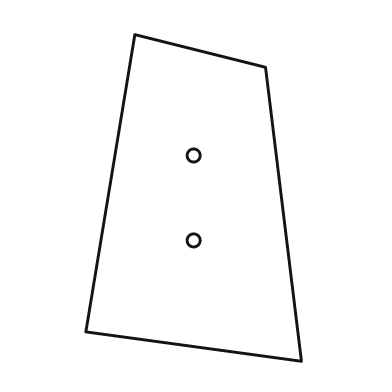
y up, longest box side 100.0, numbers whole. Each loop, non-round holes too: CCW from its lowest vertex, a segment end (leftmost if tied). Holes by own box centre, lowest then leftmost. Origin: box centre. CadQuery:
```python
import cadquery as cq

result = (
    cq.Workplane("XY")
    .moveTo(33.0, -50.0)
    .lineTo(22.0, 40.0)
    .lineTo(-18.0, 50.0)
    .lineTo(-33.0, -41.0)
    .close()
    .moveTo(0.0, -13.0)
    .circle(2.0)
    .moveTo(0.0, 13.0)
    .circle(2.0)
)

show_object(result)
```